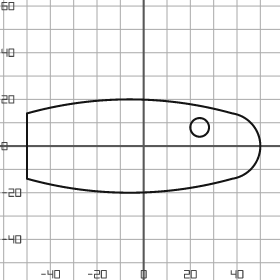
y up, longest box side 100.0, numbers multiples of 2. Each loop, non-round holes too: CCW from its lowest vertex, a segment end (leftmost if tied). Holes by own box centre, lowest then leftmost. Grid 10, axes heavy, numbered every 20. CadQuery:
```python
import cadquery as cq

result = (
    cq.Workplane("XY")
    .moveTo(-50.0, -14.0)
    .threePointArc((-6.0, -20.0), (38.0, -14.0))
    .threePointArc((50.0, 0.0), (38.0, 14.0))
    .threePointArc((-6.0, 20.0), (-50.0, 14.0))
    .close()
    .moveTo(24.0, 8.0)
    .circle(4.0)
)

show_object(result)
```